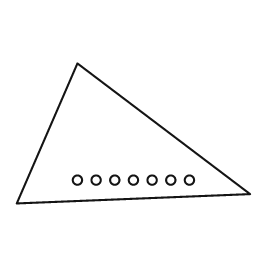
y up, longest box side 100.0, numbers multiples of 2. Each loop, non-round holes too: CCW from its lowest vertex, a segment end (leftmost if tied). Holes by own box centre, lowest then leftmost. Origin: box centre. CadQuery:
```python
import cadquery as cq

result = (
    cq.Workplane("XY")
    .moveTo(-50.0, -30.0)
    .lineTo(50.0, -26.0)
    .lineTo(-24.0, 30.0)
    .close()
    .moveTo(-24.0, -20.0)
    .circle(2.0)
    .moveTo(-16.0, -20.0)
    .circle(2.0)
    .moveTo(-8.0, -20.0)
    .circle(2.0)
    .moveTo(0.0, -20.0)
    .circle(2.0)
    .moveTo(8.0, -20.0)
    .circle(2.0)
    .moveTo(16.0, -20.0)
    .circle(2.0)
    .moveTo(24.0, -20.0)
    .circle(2.0)
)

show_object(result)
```